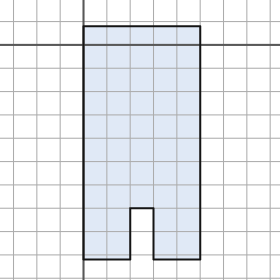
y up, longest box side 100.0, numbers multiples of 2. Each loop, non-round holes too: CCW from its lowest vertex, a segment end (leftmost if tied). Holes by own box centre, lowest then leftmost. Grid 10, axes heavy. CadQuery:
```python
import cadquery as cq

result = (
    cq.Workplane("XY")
    .moveTo(0.0, -92.0)
    .lineTo(20.0, -92.0)
    .lineTo(20.0, -70.0)
    .lineTo(30.0, -70.0)
    .lineTo(30.0, -92.0)
    .lineTo(50.0, -92.0)
    .lineTo(50.0, 8.0)
    .lineTo(0.0, 8.0)
    .close()
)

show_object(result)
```